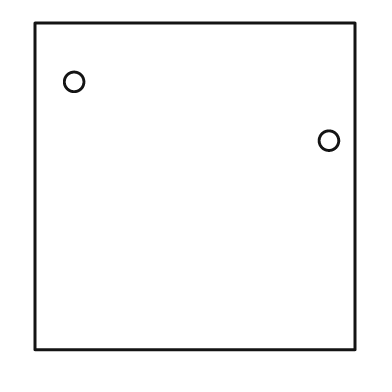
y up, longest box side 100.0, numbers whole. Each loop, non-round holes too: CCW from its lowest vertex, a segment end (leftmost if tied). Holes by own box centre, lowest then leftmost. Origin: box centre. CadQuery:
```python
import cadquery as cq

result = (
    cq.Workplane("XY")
    .moveTo(-49.0, -50.0)
    .lineTo(49.0, -50.0)
    .lineTo(49.0, 50.0)
    .lineTo(-49.0, 50.0)
    .close()
    .moveTo(41.0, 14.0)
    .circle(3.0)
    .moveTo(-37.0, 32.0)
    .circle(3.0)
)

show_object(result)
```